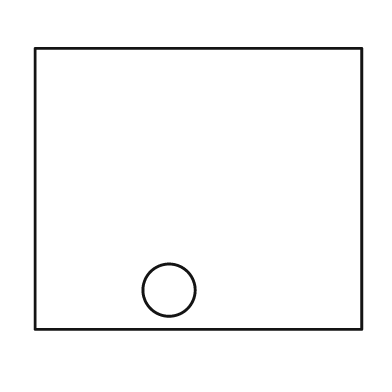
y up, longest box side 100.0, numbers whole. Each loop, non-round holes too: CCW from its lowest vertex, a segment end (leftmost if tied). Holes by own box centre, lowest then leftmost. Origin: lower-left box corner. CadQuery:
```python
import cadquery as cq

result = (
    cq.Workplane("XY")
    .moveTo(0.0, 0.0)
    .lineTo(100.0, 0.0)
    .lineTo(100.0, 86.0)
    .lineTo(0.0, 86.0)
    .close()
    .moveTo(41.0, 12.0)
    .circle(8.0)
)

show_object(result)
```